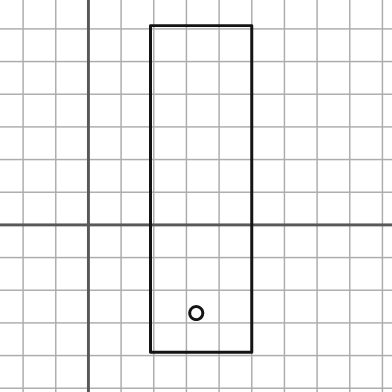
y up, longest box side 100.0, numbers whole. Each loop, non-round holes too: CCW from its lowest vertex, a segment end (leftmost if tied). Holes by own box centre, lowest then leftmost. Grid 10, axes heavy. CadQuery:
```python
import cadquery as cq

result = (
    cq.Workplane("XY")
    .moveTo(19.0, -39.0)
    .lineTo(50.0, -39.0)
    .lineTo(50.0, 61.0)
    .lineTo(19.0, 61.0)
    .close()
    .moveTo(33.0, -27.0)
    .circle(2.0)
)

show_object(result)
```